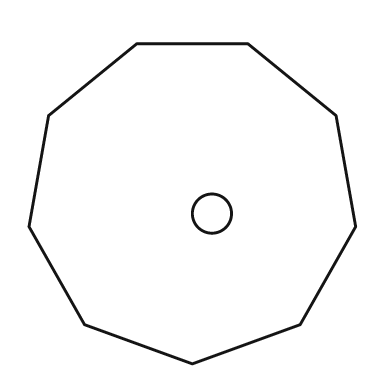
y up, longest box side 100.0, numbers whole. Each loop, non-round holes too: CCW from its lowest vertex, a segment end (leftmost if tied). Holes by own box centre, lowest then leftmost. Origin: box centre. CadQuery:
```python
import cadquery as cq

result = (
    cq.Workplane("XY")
    .moveTo(0.0, -49.0)
    .lineTo(33.0, -37.0)
    .lineTo(50.0, -7.0)
    .lineTo(44.0, 27.0)
    .lineTo(17.0, 49.0)
    .lineTo(-17.0, 49.0)
    .lineTo(-44.0, 27.0)
    .lineTo(-50.0, -7.0)
    .lineTo(-33.0, -37.0)
    .close()
    .moveTo(6.0, -3.0)
    .circle(6.0)
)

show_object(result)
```